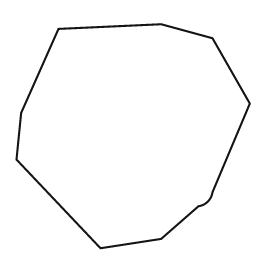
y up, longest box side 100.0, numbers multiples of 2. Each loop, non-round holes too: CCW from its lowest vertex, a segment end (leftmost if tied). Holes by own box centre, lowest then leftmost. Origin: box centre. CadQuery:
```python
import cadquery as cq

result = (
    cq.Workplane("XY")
    .moveTo(-14.0, -48.0)
    .lineTo(12.0, -44.0)
    .lineTo(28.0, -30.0)
    .threePointArc((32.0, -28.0), (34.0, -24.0))
    .lineTo(50.0, 14.0)
    .lineTo(34.0, 42.0)
    .lineTo(12.0, 48.0)
    .lineTo(-32.0, 46.0)
    .lineTo(-48.0, 10.0)
    .lineTo(-50.0, -10.0)
    .close()
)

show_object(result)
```